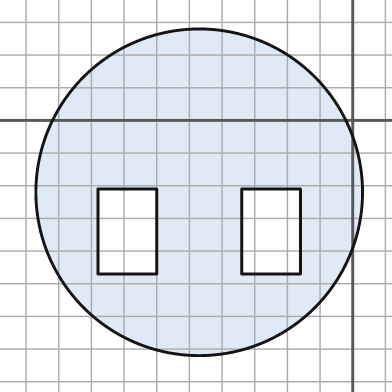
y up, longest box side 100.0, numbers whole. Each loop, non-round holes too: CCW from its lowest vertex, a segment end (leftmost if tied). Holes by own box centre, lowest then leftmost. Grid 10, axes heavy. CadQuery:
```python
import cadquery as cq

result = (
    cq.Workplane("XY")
    .moveTo(-47.0, -22.0)
    .circle(50.0)
    .moveTo(-78.0, -47.0)
    .lineTo(-60.0, -47.0)
    .lineTo(-60.0, -21.0)
    .lineTo(-78.0, -21.0)
    .close()
    .moveTo(-34.0, -47.0)
    .lineTo(-16.0, -47.0)
    .lineTo(-16.0, -21.0)
    .lineTo(-34.0, -21.0)
    .close()
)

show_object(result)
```